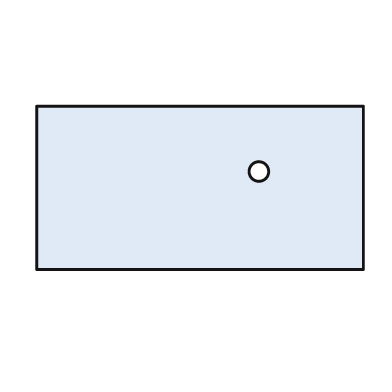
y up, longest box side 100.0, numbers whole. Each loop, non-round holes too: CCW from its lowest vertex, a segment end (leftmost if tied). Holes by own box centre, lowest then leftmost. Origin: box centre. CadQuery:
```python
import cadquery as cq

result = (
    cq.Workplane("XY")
    .moveTo(-50.0, -25.0)
    .lineTo(50.0, -25.0)
    .lineTo(50.0, 25.0)
    .lineTo(-50.0, 25.0)
    .close()
    .moveTo(18.0, 5.0)
    .circle(3.0)
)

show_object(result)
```